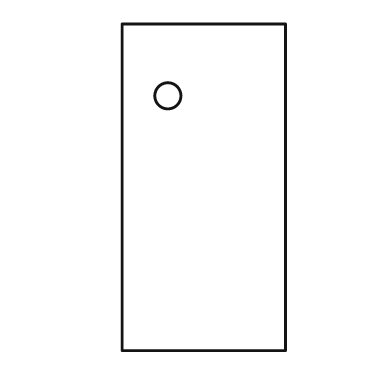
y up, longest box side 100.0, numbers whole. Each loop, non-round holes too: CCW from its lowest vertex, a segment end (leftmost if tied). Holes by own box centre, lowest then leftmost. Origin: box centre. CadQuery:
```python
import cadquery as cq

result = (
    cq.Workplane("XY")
    .moveTo(-25.0, -50.0)
    .lineTo(25.0, -50.0)
    .lineTo(25.0, 50.0)
    .lineTo(-25.0, 50.0)
    .close()
    .moveTo(-11.0, 28.0)
    .circle(4.0)
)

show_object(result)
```